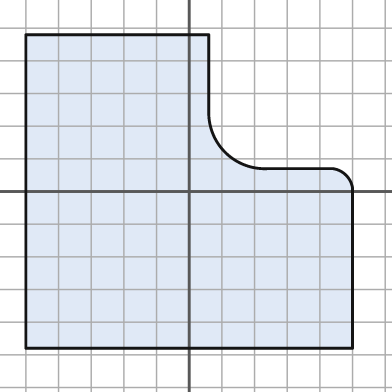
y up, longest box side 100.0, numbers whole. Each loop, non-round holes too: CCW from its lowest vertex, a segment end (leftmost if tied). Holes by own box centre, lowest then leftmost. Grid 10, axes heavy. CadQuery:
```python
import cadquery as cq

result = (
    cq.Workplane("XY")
    .moveTo(-50.0, -48.0)
    .lineTo(50.0, -48.0)
    .lineTo(50.0, 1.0)
    .threePointArc((48.0, 5.0), (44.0, 7.0))
    .lineTo(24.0, 7.0)
    .threePointArc((11.0, 12.0), (6.0, 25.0))
    .lineTo(6.0, 48.0)
    .lineTo(-50.0, 48.0)
    .close()
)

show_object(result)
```